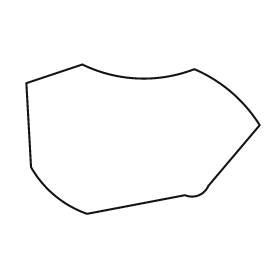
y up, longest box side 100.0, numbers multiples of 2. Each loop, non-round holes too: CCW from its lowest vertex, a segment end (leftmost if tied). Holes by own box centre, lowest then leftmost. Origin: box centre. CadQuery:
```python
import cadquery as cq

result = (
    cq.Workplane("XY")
    .moveTo(-24.0, -32.0)
    .lineTo(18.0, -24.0)
    .threePointArc((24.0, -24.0), (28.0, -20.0))
    .lineTo(50.0, 6.0)
    .threePointArc((38.0, 20.0), (22.0, 30.0))
    .threePointArc((-2.0, 26.0), (-26.0, 32.0))
    .lineTo(-50.0, 24.0)
    .lineTo(-48.0, -12.0)
    .threePointArc((-38.0, -24.0), (-24.0, -32.0))
    .close()
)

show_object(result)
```